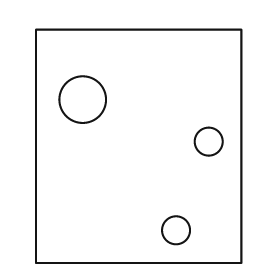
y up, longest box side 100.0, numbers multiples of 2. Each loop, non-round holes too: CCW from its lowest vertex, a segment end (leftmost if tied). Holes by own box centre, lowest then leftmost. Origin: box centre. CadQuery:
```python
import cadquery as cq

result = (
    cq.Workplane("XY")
    .moveTo(-44.0, -50.0)
    .lineTo(44.0, -50.0)
    .lineTo(44.0, 50.0)
    .lineTo(-44.0, 50.0)
    .close()
    .moveTo(16.0, -36.0)
    .circle(6.0)
    .moveTo(30.0, 2.0)
    .circle(6.0)
    .moveTo(-24.0, 20.0)
    .circle(10.0)
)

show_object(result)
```